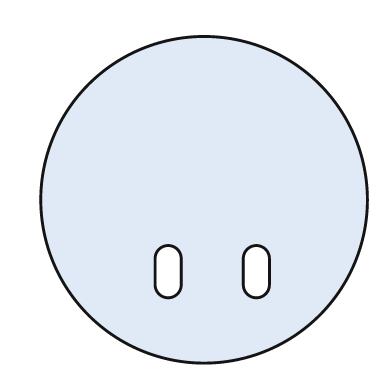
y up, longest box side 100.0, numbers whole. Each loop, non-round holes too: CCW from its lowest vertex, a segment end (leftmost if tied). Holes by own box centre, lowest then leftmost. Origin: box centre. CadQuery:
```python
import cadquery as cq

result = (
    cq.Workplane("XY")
    .moveTo(0.0, 0.0)
    .circle(50.0)
    .moveTo(-15.0, -26.0)
    .threePointArc((-11.0, -30.0), (-7.0, -26.0))
    .lineTo(-7.0, -18.0)
    .threePointArc((-11.0, -14.0), (-15.0, -18.0))
    .close()
    .moveTo(12.0, -26.0)
    .threePointArc((16.0, -30.0), (20.0, -26.0))
    .lineTo(20.0, -18.0)
    .threePointArc((16.0, -14.0), (12.0, -18.0))
    .close()
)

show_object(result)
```